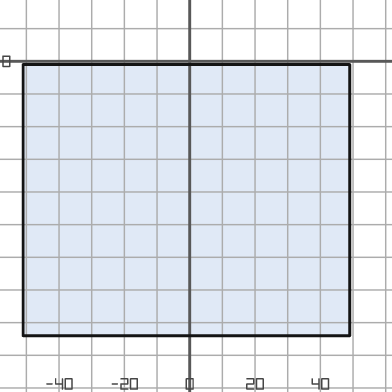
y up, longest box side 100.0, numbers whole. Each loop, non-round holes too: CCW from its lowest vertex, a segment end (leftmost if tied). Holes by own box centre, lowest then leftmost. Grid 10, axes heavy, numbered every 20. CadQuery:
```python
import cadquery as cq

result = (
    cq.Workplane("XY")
    .moveTo(-51.0, -84.0)
    .lineTo(49.0, -84.0)
    .lineTo(49.0, -1.0)
    .lineTo(-51.0, -1.0)
    .close()
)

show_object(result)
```